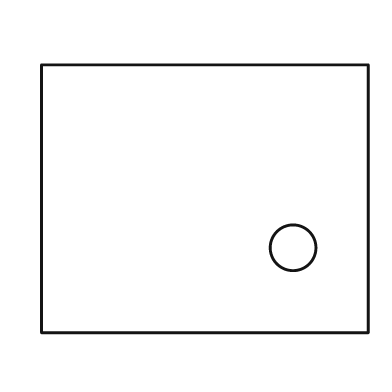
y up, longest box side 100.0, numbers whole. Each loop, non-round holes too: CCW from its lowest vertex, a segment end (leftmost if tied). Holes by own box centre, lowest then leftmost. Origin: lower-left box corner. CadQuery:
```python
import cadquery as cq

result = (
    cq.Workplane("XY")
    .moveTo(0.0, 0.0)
    .lineTo(100.0, 0.0)
    .lineTo(100.0, 82.0)
    .lineTo(0.0, 82.0)
    .close()
    .moveTo(77.0, 26.0)
    .circle(7.0)
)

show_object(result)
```